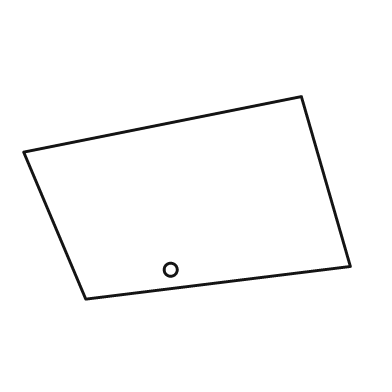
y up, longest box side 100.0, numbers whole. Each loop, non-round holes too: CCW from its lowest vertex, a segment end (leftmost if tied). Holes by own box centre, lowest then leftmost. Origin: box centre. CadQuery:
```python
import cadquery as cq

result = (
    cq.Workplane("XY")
    .moveTo(-31.0, -31.0)
    .lineTo(50.0, -21.0)
    .lineTo(35.0, 31.0)
    .lineTo(-50.0, 14.0)
    .close()
    .moveTo(-5.0, -22.0)
    .circle(2.0)
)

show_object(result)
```